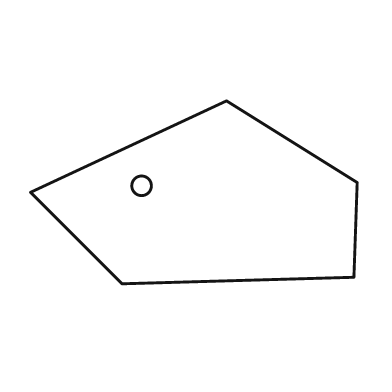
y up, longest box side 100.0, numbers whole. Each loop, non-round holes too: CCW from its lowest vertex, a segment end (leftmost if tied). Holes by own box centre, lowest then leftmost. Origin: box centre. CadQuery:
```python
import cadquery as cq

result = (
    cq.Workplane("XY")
    .moveTo(-22.0, -28.0)
    .lineTo(49.0, -26.0)
    .lineTo(50.0, 3.0)
    .lineTo(10.0, 28.0)
    .lineTo(-50.0, 0.0)
    .close()
    .moveTo(-16.0, 2.0)
    .circle(3.0)
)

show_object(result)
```